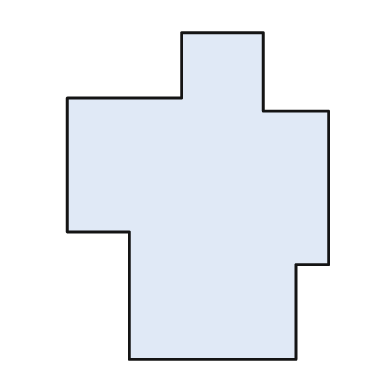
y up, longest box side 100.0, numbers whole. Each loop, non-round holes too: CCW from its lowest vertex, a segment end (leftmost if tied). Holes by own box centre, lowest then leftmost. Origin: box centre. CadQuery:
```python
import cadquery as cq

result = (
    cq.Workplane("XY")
    .moveTo(-21.0, -50.0)
    .lineTo(30.0, -50.0)
    .lineTo(30.0, -21.0)
    .lineTo(40.0, -21.0)
    .lineTo(40.0, 26.0)
    .lineTo(20.0, 26.0)
    .lineTo(20.0, 50.0)
    .lineTo(-5.0, 50.0)
    .lineTo(-5.0, 30.0)
    .lineTo(-40.0, 30.0)
    .lineTo(-40.0, -11.0)
    .lineTo(-21.0, -11.0)
    .close()
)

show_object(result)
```